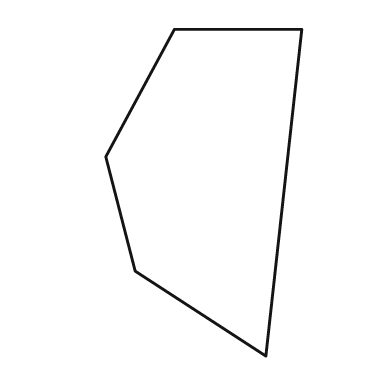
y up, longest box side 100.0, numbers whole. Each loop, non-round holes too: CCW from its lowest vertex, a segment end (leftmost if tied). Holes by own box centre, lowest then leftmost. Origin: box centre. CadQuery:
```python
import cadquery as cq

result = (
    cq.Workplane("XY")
    .moveTo(19.0, -50.0)
    .lineTo(30.0, 50.0)
    .lineTo(-9.0, 50.0)
    .lineTo(-30.0, 11.0)
    .lineTo(-21.0, -24.0)
    .close()
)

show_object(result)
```